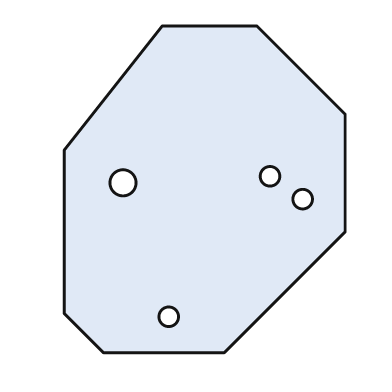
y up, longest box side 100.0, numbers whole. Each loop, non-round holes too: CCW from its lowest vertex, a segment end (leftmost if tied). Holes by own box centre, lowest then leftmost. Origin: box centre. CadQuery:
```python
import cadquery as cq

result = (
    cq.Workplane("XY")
    .moveTo(-31.0, -50.0)
    .lineTo(6.0, -50.0)
    .lineTo(43.0, -13.0)
    .lineTo(43.0, 23.0)
    .lineTo(16.0, 50.0)
    .lineTo(-13.0, 50.0)
    .lineTo(-43.0, 12.0)
    .lineTo(-43.0, -38.0)
    .close()
    .moveTo(-11.0, -39.0)
    .circle(3.0)
    .moveTo(30.0, -3.0)
    .circle(3.0)
    .moveTo(-25.0, 2.0)
    .circle(4.0)
    .moveTo(20.0, 4.0)
    .circle(3.0)
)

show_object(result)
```